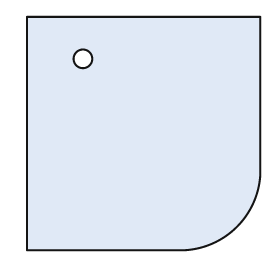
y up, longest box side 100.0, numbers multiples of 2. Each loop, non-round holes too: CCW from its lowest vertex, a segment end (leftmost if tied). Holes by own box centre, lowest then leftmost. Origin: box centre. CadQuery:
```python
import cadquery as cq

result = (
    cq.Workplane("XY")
    .moveTo(-50.0, -50.0)
    .lineTo(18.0, -50.0)
    .threePointArc((40.0, -40.0), (50.0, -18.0))
    .lineTo(50.0, 50.0)
    .lineTo(-50.0, 50.0)
    .close()
    .moveTo(-26.0, 32.0)
    .circle(4.0)
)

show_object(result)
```